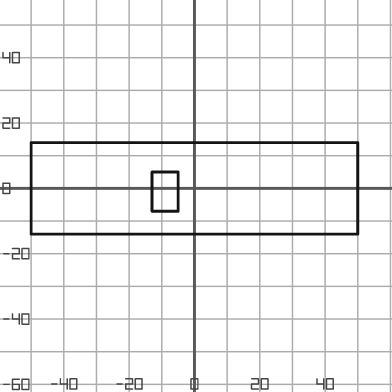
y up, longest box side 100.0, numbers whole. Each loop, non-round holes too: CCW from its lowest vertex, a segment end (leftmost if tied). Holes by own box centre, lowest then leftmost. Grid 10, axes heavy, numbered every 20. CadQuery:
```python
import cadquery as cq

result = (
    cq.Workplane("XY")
    .moveTo(-50.0, -14.0)
    .lineTo(50.0, -14.0)
    .lineTo(50.0, 14.0)
    .lineTo(-50.0, 14.0)
    .close()
    .moveTo(-13.0, -7.0)
    .lineTo(-5.0, -7.0)
    .lineTo(-5.0, 5.0)
    .lineTo(-13.0, 5.0)
    .close()
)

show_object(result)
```